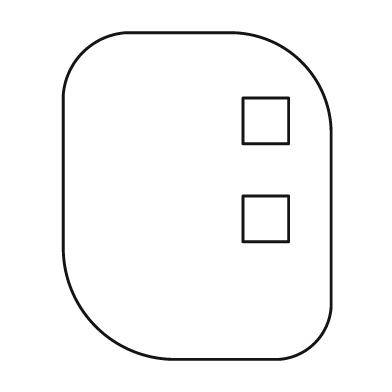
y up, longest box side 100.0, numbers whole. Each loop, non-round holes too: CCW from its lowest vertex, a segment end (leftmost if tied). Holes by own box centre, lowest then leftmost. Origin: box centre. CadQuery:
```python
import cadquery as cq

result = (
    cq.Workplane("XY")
    .moveTo(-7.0, -50.0)
    .lineTo(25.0, -50.0)
    .threePointArc((36.0, -45.0), (41.0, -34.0))
    .lineTo(41.0, 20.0)
    .threePointArc((32.0, 41.0), (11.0, 50.0))
    .lineTo(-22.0, 50.0)
    .threePointArc((-35.0, 44.0), (-41.0, 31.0))
    .lineTo(-41.0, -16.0)
    .threePointArc((-31.0, -40.0), (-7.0, -50.0))
    .close()
    .moveTo(14.0, -14.0)
    .lineTo(28.0, -14.0)
    .lineTo(28.0, 0.0)
    .lineTo(14.0, 0.0)
    .close()
    .moveTo(14.0, 16.0)
    .lineTo(28.0, 16.0)
    .lineTo(28.0, 30.0)
    .lineTo(14.0, 30.0)
    .close()
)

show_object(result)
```